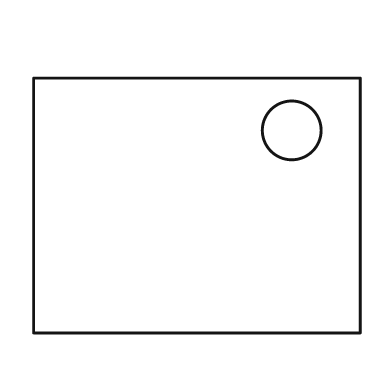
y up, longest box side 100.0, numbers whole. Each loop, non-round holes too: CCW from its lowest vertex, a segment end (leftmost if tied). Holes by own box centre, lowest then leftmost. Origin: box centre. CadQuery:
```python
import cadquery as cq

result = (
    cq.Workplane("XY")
    .moveTo(-50.0, -39.0)
    .lineTo(50.0, -39.0)
    .lineTo(50.0, 39.0)
    .lineTo(-50.0, 39.0)
    .close()
    .moveTo(29.0, 23.0)
    .circle(9.0)
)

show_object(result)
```